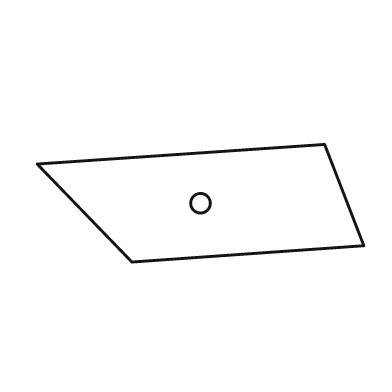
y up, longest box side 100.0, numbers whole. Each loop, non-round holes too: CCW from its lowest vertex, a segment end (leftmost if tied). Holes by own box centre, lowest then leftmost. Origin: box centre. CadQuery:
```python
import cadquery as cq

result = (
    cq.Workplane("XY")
    .moveTo(-21.0, -18.0)
    .lineTo(50.0, -13.0)
    .lineTo(38.0, 18.0)
    .lineTo(-50.0, 12.0)
    .close()
    .moveTo(0.0, 0.0)
    .circle(3.0)
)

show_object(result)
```